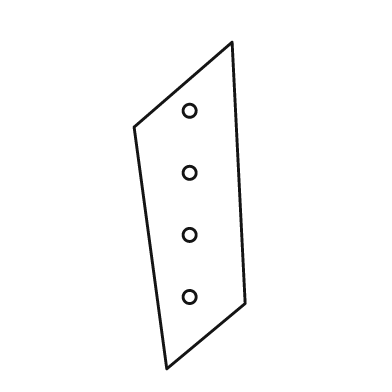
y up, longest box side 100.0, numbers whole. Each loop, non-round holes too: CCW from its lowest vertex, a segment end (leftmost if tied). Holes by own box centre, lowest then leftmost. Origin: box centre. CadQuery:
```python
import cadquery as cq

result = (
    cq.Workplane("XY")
    .moveTo(-7.0, -50.0)
    .lineTo(17.0, -30.0)
    .lineTo(13.0, 50.0)
    .lineTo(-17.0, 24.0)
    .close()
    .moveTo(0.0, -28.0)
    .circle(2.0)
    .moveTo(0.0, -9.0)
    .circle(2.0)
    .moveTo(0.0, 10.0)
    .circle(2.0)
    .moveTo(0.0, 29.0)
    .circle(2.0)
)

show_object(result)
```